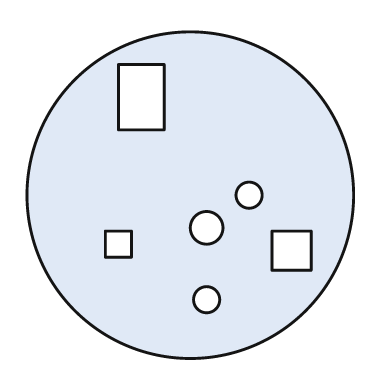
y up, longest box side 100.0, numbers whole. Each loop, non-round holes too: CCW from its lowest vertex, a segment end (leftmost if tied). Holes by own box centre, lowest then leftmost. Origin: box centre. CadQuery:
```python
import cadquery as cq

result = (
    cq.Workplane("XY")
    .moveTo(0.0, 0.0)
    .circle(50.0)
    .moveTo(5.0, -32.0)
    .circle(4.0)
    .moveTo(25.0, -23.0)
    .lineTo(37.0, -23.0)
    .lineTo(37.0, -11.0)
    .lineTo(25.0, -11.0)
    .close()
    .moveTo(-26.0, -19.0)
    .lineTo(-18.0, -19.0)
    .lineTo(-18.0, -11.0)
    .lineTo(-26.0, -11.0)
    .close()
    .moveTo(5.0, -10.0)
    .circle(5.0)
    .moveTo(18.0, 0.0)
    .circle(4.0)
    .moveTo(-22.0, 20.0)
    .lineTo(-8.0, 20.0)
    .lineTo(-8.0, 40.0)
    .lineTo(-22.0, 40.0)
    .close()
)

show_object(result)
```